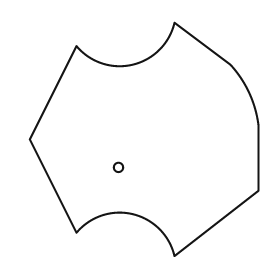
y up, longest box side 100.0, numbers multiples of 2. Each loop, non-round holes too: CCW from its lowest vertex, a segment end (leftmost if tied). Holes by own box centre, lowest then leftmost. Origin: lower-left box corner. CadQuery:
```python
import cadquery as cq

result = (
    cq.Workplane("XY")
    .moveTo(62.0, 0.0)
    .lineTo(98.0, 28.0)
    .lineTo(98.0, 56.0)
    .threePointArc((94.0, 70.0), (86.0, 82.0))
    .lineTo(62.0, 100.0)
    .threePointArc((44.0, 82.0), (20.0, 90.0))
    .lineTo(0.0, 50.0)
    .lineTo(20.0, 10.0)
    .threePointArc((44.0, 18.0), (62.0, 0.0))
    .close()
    .moveTo(38.0, 38.0)
    .circle(2.0)
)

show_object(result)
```